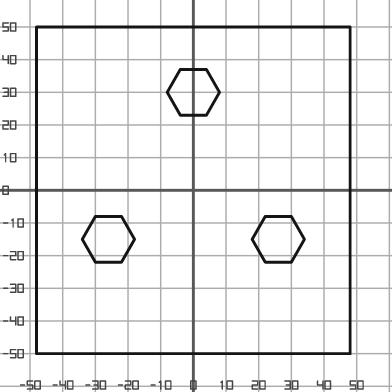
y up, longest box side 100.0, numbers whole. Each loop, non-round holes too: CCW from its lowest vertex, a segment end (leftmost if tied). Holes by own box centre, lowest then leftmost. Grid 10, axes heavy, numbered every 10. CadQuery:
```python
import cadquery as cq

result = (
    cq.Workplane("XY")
    .moveTo(-48.0, -50.0)
    .lineTo(48.0, -50.0)
    .lineTo(48.0, 50.0)
    .lineTo(-48.0, 50.0)
    .close()
    .moveTo(-30.0, -22.0)
    .lineTo(-22.0, -22.0)
    .lineTo(-18.0, -15.0)
    .lineTo(-22.0, -8.0)
    .lineTo(-30.0, -8.0)
    .lineTo(-34.0, -15.0)
    .close()
    .moveTo(22.0, -22.0)
    .lineTo(30.0, -22.0)
    .lineTo(34.0, -15.0)
    .lineTo(30.0, -8.0)
    .lineTo(22.0, -8.0)
    .lineTo(18.0, -15.0)
    .close()
    .moveTo(-4.0, 23.0)
    .lineTo(4.0, 23.0)
    .lineTo(8.0, 30.0)
    .lineTo(4.0, 37.0)
    .lineTo(-4.0, 37.0)
    .lineTo(-8.0, 30.0)
    .close()
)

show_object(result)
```